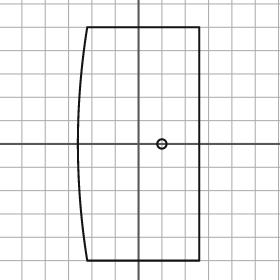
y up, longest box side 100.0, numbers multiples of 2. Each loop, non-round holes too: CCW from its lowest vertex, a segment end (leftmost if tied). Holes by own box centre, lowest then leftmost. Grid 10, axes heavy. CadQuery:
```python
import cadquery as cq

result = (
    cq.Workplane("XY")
    .moveTo(-22.0, -50.0)
    .lineTo(26.0, -50.0)
    .lineTo(26.0, 50.0)
    .lineTo(-22.0, 50.0)
    .threePointArc((-26.0, 0.0), (-22.0, -50.0))
    .close()
    .moveTo(10.0, 0.0)
    .circle(2.0)
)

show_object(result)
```